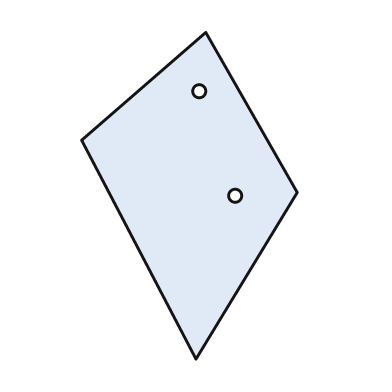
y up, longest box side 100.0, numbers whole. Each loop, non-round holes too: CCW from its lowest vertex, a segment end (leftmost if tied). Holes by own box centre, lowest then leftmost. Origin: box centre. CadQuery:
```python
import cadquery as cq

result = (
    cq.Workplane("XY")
    .moveTo(2.0, -50.0)
    .lineTo(33.0, 1.0)
    .lineTo(5.0, 50.0)
    .lineTo(-33.0, 17.0)
    .close()
    .moveTo(14.0, 0.0)
    .circle(2.0)
    .moveTo(3.0, 32.0)
    .circle(2.0)
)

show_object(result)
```